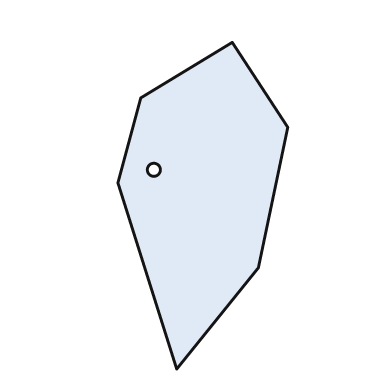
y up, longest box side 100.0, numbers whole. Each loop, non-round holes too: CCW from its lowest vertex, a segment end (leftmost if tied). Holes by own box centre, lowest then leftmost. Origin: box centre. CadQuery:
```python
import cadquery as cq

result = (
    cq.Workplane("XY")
    .moveTo(-8.0, -50.0)
    .lineTo(17.0, -19.0)
    .lineTo(26.0, 24.0)
    .lineTo(9.0, 50.0)
    .lineTo(-19.0, 33.0)
    .lineTo(-26.0, 7.0)
    .close()
    .moveTo(-15.0, 11.0)
    .circle(2.0)
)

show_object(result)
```